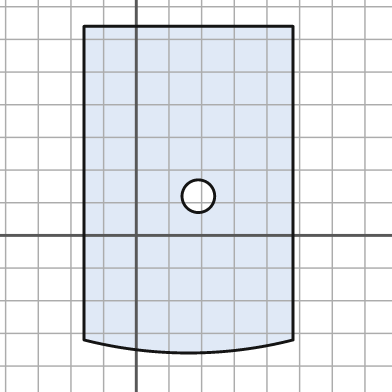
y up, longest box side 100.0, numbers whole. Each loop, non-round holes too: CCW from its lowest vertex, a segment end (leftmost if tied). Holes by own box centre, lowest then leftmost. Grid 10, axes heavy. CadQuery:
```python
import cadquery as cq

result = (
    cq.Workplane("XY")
    .moveTo(-16.0, -32.0)
    .threePointArc((16.0, -36.0), (48.0, -32.0))
    .lineTo(48.0, 64.0)
    .lineTo(-16.0, 64.0)
    .close()
    .moveTo(19.0, 12.0)
    .circle(5.0)
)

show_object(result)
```